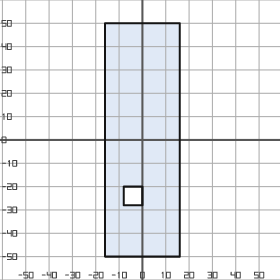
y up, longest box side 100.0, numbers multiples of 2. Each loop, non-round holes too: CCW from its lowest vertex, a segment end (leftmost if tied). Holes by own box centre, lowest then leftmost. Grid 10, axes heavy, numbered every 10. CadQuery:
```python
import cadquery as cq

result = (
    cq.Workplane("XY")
    .moveTo(-16.0, -50.0)
    .lineTo(16.0, -50.0)
    .lineTo(16.0, 50.0)
    .lineTo(-16.0, 50.0)
    .close()
    .moveTo(-8.0, -28.0)
    .lineTo(0.0, -28.0)
    .lineTo(0.0, -20.0)
    .lineTo(-8.0, -20.0)
    .close()
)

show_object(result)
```